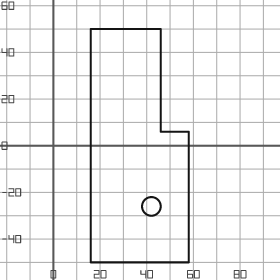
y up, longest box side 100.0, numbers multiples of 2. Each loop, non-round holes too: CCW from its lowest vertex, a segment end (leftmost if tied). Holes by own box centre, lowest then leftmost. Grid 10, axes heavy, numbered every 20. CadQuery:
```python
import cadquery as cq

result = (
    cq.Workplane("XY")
    .moveTo(16.0, -50.0)
    .lineTo(58.0, -50.0)
    .lineTo(58.0, 6.0)
    .lineTo(46.0, 6.0)
    .lineTo(46.0, 50.0)
    .lineTo(16.0, 50.0)
    .close()
    .moveTo(42.0, -26.0)
    .circle(4.0)
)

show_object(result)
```